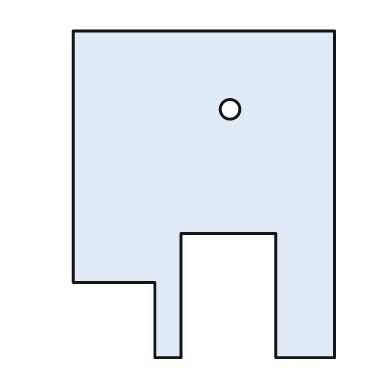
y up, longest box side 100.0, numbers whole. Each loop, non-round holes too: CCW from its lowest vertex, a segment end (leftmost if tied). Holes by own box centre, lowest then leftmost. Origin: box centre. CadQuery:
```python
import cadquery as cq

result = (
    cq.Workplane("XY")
    .moveTo(-15.0, -50.0)
    .lineTo(-7.0, -50.0)
    .lineTo(-7.0, -12.0)
    .lineTo(22.0, -12.0)
    .lineTo(22.0, -50.0)
    .lineTo(40.0, -50.0)
    .lineTo(40.0, 50.0)
    .lineTo(-40.0, 50.0)
    .lineTo(-40.0, -27.0)
    .lineTo(-15.0, -27.0)
    .close()
    .moveTo(8.0, 26.0)
    .circle(3.0)
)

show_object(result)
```